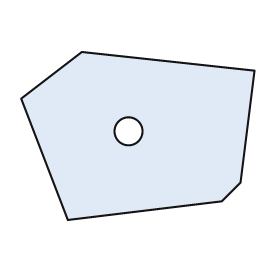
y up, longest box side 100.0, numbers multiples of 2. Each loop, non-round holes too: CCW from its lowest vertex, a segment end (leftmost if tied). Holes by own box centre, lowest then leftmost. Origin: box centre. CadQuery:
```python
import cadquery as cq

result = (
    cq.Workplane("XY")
    .moveTo(-30.0, -36.0)
    .lineTo(36.0, -28.0)
    .lineTo(44.0, -20.0)
    .lineTo(50.0, 28.0)
    .lineTo(-24.0, 36.0)
    .lineTo(-50.0, 16.0)
    .close()
    .moveTo(-4.0, 2.0)
    .circle(6.0)
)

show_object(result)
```